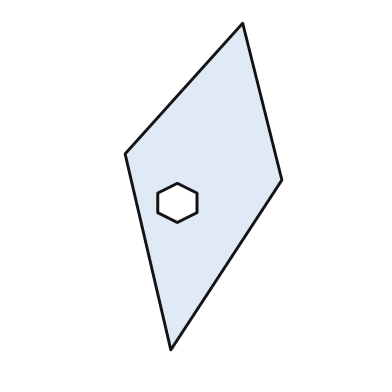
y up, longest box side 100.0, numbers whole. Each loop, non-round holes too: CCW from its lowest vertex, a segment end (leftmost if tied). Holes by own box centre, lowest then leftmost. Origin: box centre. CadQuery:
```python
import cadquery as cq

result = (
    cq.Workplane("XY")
    .moveTo(-10.0, -50.0)
    .lineTo(24.0, 2.0)
    .lineTo(12.0, 50.0)
    .lineTo(-24.0, 10.0)
    .close()
    .moveTo(-8.0, -11.0)
    .lineTo(-2.0, -8.0)
    .lineTo(-2.0, -2.0)
    .lineTo(-8.0, 1.0)
    .lineTo(-14.0, -2.0)
    .lineTo(-14.0, -8.0)
    .close()
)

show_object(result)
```